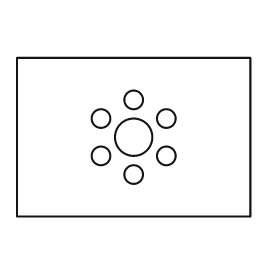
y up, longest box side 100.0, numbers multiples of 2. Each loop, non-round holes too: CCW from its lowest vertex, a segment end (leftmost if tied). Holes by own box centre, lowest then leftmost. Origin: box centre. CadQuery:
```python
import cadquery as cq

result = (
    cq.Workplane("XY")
    .moveTo(-50.0, -34.0)
    .lineTo(50.0, -34.0)
    .lineTo(50.0, 34.0)
    .lineTo(-50.0, 34.0)
    .close()
    .moveTo(0.0, -16.0)
    .circle(4.0)
    .moveTo(-14.0, -8.0)
    .circle(4.0)
    .moveTo(14.0, -8.0)
    .circle(4.0)
    .moveTo(0.0, 0.0)
    .circle(8.0)
    .moveTo(-14.0, 8.0)
    .circle(4.0)
    .moveTo(14.0, 8.0)
    .circle(4.0)
    .moveTo(0.0, 16.0)
    .circle(4.0)
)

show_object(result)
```